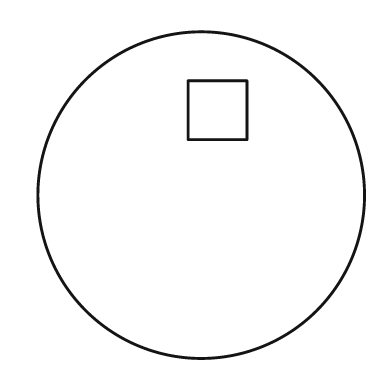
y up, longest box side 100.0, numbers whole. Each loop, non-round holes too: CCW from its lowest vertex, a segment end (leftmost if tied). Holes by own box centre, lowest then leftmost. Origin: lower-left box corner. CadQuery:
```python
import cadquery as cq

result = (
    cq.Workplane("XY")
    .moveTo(50.0, 50.0)
    .circle(50.0)
    .moveTo(46.0, 67.0)
    .lineTo(64.0, 67.0)
    .lineTo(64.0, 85.0)
    .lineTo(46.0, 85.0)
    .close()
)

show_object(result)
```